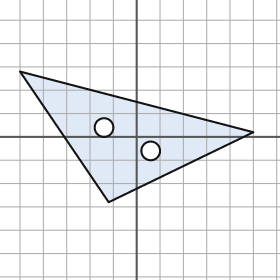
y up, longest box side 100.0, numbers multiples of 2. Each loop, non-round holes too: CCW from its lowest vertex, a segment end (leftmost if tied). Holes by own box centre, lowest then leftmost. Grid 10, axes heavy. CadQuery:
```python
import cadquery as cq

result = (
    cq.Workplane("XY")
    .moveTo(-12.0, -28.0)
    .lineTo(50.0, 2.0)
    .lineTo(-50.0, 28.0)
    .close()
    .moveTo(6.0, -6.0)
    .circle(4.0)
    .moveTo(-14.0, 4.0)
    .circle(4.0)
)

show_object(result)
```